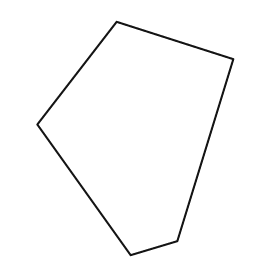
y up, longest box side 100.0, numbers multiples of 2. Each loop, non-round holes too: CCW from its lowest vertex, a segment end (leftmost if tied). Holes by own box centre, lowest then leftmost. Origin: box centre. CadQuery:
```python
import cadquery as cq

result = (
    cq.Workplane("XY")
    .moveTo(-2.0, -50.0)
    .lineTo(18.0, -44.0)
    .lineTo(42.0, 34.0)
    .lineTo(-8.0, 50.0)
    .lineTo(-42.0, 6.0)
    .close()
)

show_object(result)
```